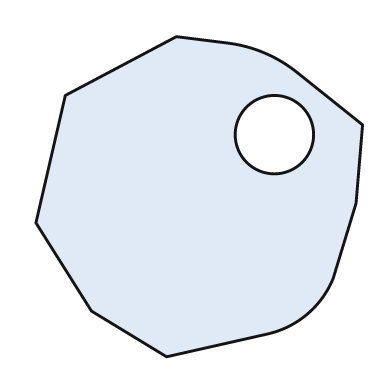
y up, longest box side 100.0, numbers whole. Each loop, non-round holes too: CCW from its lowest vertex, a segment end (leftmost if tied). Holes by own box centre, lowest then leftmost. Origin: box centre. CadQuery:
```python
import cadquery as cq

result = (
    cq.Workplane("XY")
    .moveTo(-10.0, -49.0)
    .lineTo(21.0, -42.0)
    .threePointArc((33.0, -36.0), (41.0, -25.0))
    .lineTo(48.0, -2.0)
    .lineTo(50.0, 22.0)
    .lineTo(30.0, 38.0)
    .threePointArc((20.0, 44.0), (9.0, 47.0))
    .lineTo(-7.0, 49.0)
    .lineTo(-41.0, 31.0)
    .lineTo(-50.0, -8.0)
    .lineTo(-33.0, -35.0)
    .close()
    .moveTo(23.0, 19.0)
    .circle(12.0)
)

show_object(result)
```